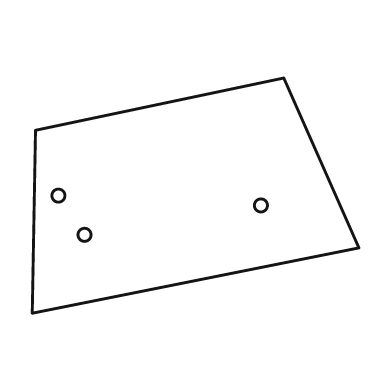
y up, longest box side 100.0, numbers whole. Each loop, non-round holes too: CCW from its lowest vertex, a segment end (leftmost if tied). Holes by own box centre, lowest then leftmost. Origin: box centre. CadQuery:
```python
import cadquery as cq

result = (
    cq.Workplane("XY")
    .moveTo(-50.0, -36.0)
    .lineTo(50.0, -16.0)
    .lineTo(27.0, 36.0)
    .lineTo(-49.0, 20.0)
    .close()
    .moveTo(-34.0, -12.0)
    .circle(2.0)
    .moveTo(20.0, -3.0)
    .circle(2.0)
    .moveTo(-42.0, 0.0)
    .circle(2.0)
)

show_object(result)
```